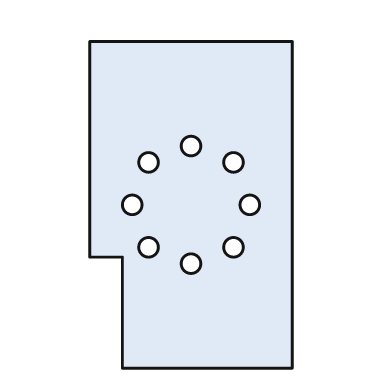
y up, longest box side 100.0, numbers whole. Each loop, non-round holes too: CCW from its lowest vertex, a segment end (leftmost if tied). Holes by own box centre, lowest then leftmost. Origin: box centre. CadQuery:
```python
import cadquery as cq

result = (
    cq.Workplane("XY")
    .moveTo(-21.0, -50.0)
    .lineTo(31.0, -50.0)
    .lineTo(31.0, 50.0)
    .lineTo(-31.0, 50.0)
    .lineTo(-31.0, -16.0)
    .lineTo(-21.0, -16.0)
    .close()
    .moveTo(0.0, -18.0)
    .circle(3.0)
    .moveTo(-13.0, -13.0)
    .circle(3.0)
    .moveTo(13.0, -13.0)
    .circle(3.0)
    .moveTo(-18.0, 0.0)
    .circle(3.0)
    .moveTo(18.0, 0.0)
    .circle(3.0)
    .moveTo(-13.0, 13.0)
    .circle(3.0)
    .moveTo(13.0, 13.0)
    .circle(3.0)
    .moveTo(0.0, 18.0)
    .circle(3.0)
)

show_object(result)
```